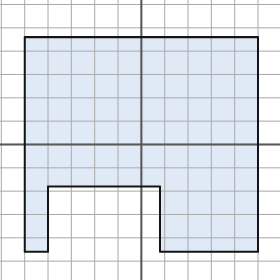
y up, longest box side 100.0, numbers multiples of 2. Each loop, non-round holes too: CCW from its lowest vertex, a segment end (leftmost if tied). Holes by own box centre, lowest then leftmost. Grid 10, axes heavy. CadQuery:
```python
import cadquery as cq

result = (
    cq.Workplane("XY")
    .moveTo(-50.0, -46.0)
    .lineTo(-40.0, -46.0)
    .lineTo(-40.0, -18.0)
    .lineTo(8.0, -18.0)
    .lineTo(8.0, -46.0)
    .lineTo(50.0, -46.0)
    .lineTo(50.0, 46.0)
    .lineTo(-50.0, 46.0)
    .close()
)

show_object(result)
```